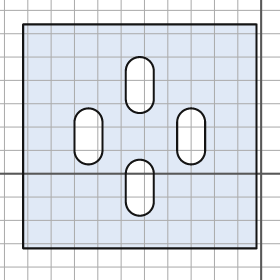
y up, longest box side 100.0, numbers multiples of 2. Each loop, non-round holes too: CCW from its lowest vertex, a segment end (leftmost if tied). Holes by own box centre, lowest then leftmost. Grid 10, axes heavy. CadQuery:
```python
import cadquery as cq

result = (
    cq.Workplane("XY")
    .moveTo(-102.0, -32.0)
    .lineTo(-2.0, -32.0)
    .lineTo(-2.0, 64.0)
    .lineTo(-102.0, 64.0)
    .close()
    .moveTo(-58.0, -12.0)
    .threePointArc((-52.0, -18.0), (-46.0, -12.0))
    .lineTo(-46.0, 0.0)
    .threePointArc((-52.0, 6.0), (-58.0, 0.0))
    .close()
    .moveTo(-80.0, 10.0)
    .threePointArc((-74.0, 4.0), (-68.0, 10.0))
    .lineTo(-68.0, 22.0)
    .threePointArc((-74.0, 28.0), (-80.0, 22.0))
    .close()
    .moveTo(-36.0, 10.0)
    .threePointArc((-30.0, 4.0), (-24.0, 10.0))
    .lineTo(-24.0, 22.0)
    .threePointArc((-30.0, 28.0), (-36.0, 22.0))
    .close()
    .moveTo(-58.0, 32.0)
    .threePointArc((-52.0, 26.0), (-46.0, 32.0))
    .lineTo(-46.0, 44.0)
    .threePointArc((-52.0, 50.0), (-58.0, 44.0))
    .close()
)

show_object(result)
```